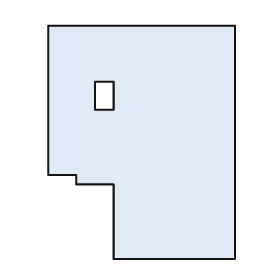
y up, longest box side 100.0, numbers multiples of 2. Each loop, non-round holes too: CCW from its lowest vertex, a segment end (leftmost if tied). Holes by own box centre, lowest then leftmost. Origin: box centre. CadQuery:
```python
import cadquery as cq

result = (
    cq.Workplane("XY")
    .moveTo(-12.0, -50.0)
    .lineTo(40.0, -50.0)
    .lineTo(40.0, 50.0)
    .lineTo(-40.0, 50.0)
    .lineTo(-40.0, -14.0)
    .lineTo(-28.0, -14.0)
    .lineTo(-28.0, -18.0)
    .lineTo(-12.0, -18.0)
    .close()
    .moveTo(-20.0, 14.0)
    .lineTo(-12.0, 14.0)
    .lineTo(-12.0, 26.0)
    .lineTo(-20.0, 26.0)
    .close()
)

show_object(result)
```